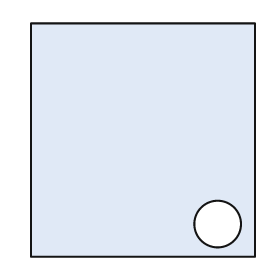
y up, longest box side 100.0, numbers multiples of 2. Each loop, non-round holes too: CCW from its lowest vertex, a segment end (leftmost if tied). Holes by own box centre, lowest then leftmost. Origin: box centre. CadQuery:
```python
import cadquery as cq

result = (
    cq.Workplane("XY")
    .moveTo(-48.0, -50.0)
    .lineTo(48.0, -50.0)
    .lineTo(48.0, 50.0)
    .lineTo(-48.0, 50.0)
    .close()
    .moveTo(32.0, -36.0)
    .circle(10.0)
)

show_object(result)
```